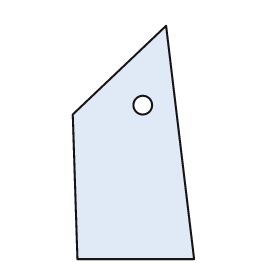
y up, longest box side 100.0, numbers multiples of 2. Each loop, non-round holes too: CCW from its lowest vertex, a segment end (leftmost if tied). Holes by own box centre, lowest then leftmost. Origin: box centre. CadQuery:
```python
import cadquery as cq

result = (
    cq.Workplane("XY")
    .moveTo(-24.0, -50.0)
    .lineTo(26.0, -50.0)
    .lineTo(14.0, 50.0)
    .lineTo(-26.0, 12.0)
    .close()
    .moveTo(4.0, 16.0)
    .circle(4.0)
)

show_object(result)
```